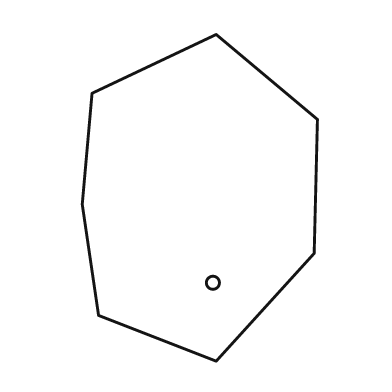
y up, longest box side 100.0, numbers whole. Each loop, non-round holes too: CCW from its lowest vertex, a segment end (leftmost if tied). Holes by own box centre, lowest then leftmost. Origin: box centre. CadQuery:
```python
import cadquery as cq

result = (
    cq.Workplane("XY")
    .moveTo(5.0, -50.0)
    .lineTo(35.0, -17.0)
    .lineTo(36.0, 24.0)
    .lineTo(5.0, 50.0)
    .lineTo(-33.0, 32.0)
    .lineTo(-36.0, -2.0)
    .lineTo(-31.0, -36.0)
    .close()
    .moveTo(4.0, -26.0)
    .circle(2.0)
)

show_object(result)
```